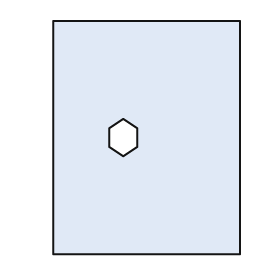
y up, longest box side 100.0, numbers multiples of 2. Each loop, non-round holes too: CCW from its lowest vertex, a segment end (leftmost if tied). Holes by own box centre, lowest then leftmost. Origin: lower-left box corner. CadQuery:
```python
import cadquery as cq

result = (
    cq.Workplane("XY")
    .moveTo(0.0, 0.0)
    .lineTo(80.0, 0.0)
    .lineTo(80.0, 100.0)
    .lineTo(0.0, 100.0)
    .close()
    .moveTo(30.0, 42.0)
    .lineTo(36.0, 46.0)
    .lineTo(36.0, 54.0)
    .lineTo(30.0, 58.0)
    .lineTo(24.0, 54.0)
    .lineTo(24.0, 46.0)
    .close()
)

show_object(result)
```